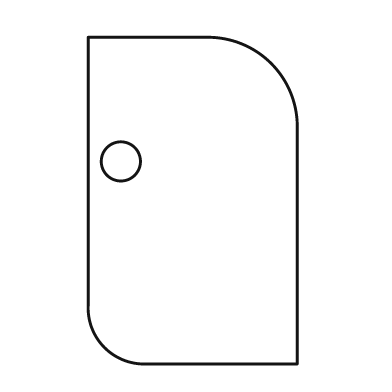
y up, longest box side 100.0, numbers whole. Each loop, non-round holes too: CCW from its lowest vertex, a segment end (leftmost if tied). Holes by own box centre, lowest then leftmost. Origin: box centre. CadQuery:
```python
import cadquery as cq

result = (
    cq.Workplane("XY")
    .moveTo(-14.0, -50.0)
    .lineTo(32.0, -50.0)
    .lineTo(32.0, 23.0)
    .threePointArc((24.0, 42.0), (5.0, 50.0))
    .lineTo(-32.0, 50.0)
    .lineTo(-32.0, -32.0)
    .threePointArc((-27.0, -45.0), (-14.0, -50.0))
    .close()
    .moveTo(-22.0, 12.0)
    .circle(6.0)
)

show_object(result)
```